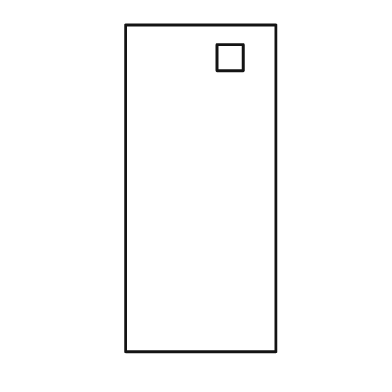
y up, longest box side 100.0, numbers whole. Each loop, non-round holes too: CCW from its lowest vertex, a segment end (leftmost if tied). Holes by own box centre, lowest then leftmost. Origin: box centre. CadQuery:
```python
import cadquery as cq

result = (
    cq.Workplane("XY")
    .moveTo(-23.0, -50.0)
    .lineTo(23.0, -50.0)
    .lineTo(23.0, 50.0)
    .lineTo(-23.0, 50.0)
    .close()
    .moveTo(5.0, 36.0)
    .lineTo(13.0, 36.0)
    .lineTo(13.0, 44.0)
    .lineTo(5.0, 44.0)
    .close()
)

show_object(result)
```